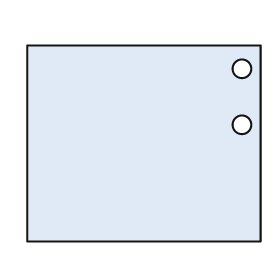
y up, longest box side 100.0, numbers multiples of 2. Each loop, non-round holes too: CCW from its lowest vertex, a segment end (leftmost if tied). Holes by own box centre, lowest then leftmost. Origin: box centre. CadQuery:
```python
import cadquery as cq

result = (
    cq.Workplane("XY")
    .moveTo(-50.0, -42.0)
    .lineTo(50.0, -42.0)
    .lineTo(50.0, 42.0)
    .lineTo(-50.0, 42.0)
    .close()
    .moveTo(42.0, 8.0)
    .circle(4.0)
    .moveTo(42.0, 32.0)
    .circle(4.0)
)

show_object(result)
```